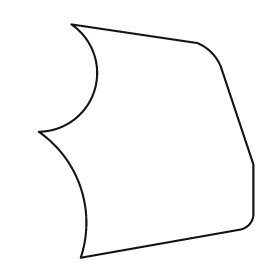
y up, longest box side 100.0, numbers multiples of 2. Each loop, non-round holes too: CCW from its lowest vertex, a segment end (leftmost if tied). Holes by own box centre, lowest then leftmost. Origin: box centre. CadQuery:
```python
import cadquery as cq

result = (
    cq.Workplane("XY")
    .moveTo(-28.0, -50.0)
    .lineTo(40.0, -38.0)
    .threePointArc((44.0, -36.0), (46.0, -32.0))
    .lineTo(46.0, -10.0)
    .lineTo(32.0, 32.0)
    .threePointArc((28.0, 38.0), (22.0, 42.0))
    .lineTo(-32.0, 50.0)
    .threePointArc((-22.0, 22.0), (-46.0, 4.0))
    .threePointArc((-28.0, -20.0), (-28.0, -50.0))
    .close()
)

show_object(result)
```